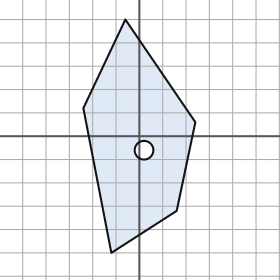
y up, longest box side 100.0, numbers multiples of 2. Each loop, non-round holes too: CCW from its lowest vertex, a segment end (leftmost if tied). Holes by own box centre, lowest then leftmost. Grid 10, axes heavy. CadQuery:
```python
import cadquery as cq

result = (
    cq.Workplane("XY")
    .moveTo(-12.0, -50.0)
    .lineTo(16.0, -32.0)
    .lineTo(24.0, 6.0)
    .lineTo(-6.0, 50.0)
    .lineTo(-24.0, 12.0)
    .close()
    .moveTo(2.0, -6.0)
    .circle(4.0)
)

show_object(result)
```